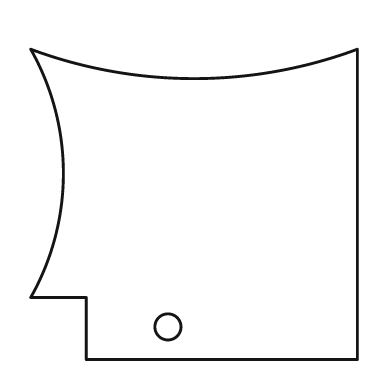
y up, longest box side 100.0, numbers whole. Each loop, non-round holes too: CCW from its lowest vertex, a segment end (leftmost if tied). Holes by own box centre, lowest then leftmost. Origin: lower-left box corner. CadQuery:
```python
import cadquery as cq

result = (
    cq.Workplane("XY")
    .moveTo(17.0, 0.0)
    .lineTo(100.0, 0.0)
    .lineTo(100.0, 95.0)
    .threePointArc((50.0, 86.0), (0.0, 95.0))
    .threePointArc((10.0, 57.0), (0.0, 19.0))
    .lineTo(17.0, 19.0)
    .close()
    .moveTo(42.0, 10.0)
    .circle(4.0)
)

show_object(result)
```